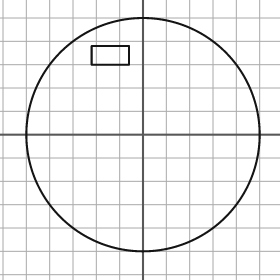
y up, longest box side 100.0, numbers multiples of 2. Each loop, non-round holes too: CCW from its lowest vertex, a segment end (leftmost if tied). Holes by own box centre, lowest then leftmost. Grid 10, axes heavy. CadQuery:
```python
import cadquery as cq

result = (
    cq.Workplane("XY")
    .moveTo(0.0, 0.0)
    .circle(50.0)
    .moveTo(-22.0, 30.0)
    .lineTo(-6.0, 30.0)
    .lineTo(-6.0, 38.0)
    .lineTo(-22.0, 38.0)
    .close()
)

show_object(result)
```